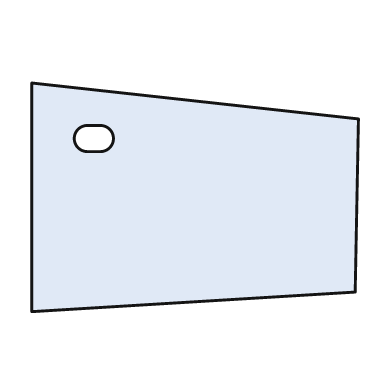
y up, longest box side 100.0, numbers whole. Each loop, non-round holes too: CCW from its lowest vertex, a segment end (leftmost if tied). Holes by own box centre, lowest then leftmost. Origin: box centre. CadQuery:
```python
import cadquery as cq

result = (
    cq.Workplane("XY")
    .moveTo(-50.0, -35.0)
    .lineTo(49.0, -29.0)
    .lineTo(50.0, 24.0)
    .lineTo(-50.0, 35.0)
    .close()
    .moveTo(-33.0, 14.0)
    .lineTo(-29.0, 14.0)
    .threePointArc((-25.0, 18.0), (-29.0, 22.0))
    .lineTo(-33.0, 22.0)
    .threePointArc((-37.0, 18.0), (-33.0, 14.0))
    .close()
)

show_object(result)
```